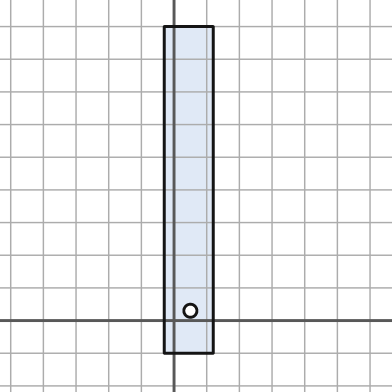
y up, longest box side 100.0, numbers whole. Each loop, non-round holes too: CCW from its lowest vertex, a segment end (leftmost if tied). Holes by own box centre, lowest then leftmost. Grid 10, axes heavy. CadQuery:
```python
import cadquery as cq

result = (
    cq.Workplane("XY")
    .moveTo(-3.0, -10.0)
    .lineTo(12.0, -10.0)
    .lineTo(12.0, 90.0)
    .lineTo(-3.0, 90.0)
    .close()
    .moveTo(5.0, 3.0)
    .circle(2.0)
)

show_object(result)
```